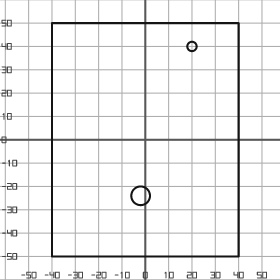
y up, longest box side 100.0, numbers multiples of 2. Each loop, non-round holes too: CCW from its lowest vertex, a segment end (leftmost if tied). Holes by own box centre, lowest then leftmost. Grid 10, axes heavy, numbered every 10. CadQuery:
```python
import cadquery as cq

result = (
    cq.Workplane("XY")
    .moveTo(-40.0, -50.0)
    .lineTo(40.0, -50.0)
    .lineTo(40.0, 50.0)
    .lineTo(-40.0, 50.0)
    .close()
    .moveTo(-2.0, -24.0)
    .circle(4.0)
    .moveTo(20.0, 40.0)
    .circle(2.0)
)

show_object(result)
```